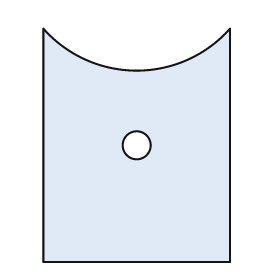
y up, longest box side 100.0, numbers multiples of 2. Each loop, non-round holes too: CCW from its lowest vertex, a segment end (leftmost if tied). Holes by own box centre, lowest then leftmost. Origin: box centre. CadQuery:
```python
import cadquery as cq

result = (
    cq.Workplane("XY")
    .moveTo(-40.0, -50.0)
    .lineTo(40.0, -50.0)
    .lineTo(40.0, 50.0)
    .threePointArc((0.0, 32.0), (-40.0, 50.0))
    .close()
    .moveTo(0.0, 0.0)
    .circle(6.0)
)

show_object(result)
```